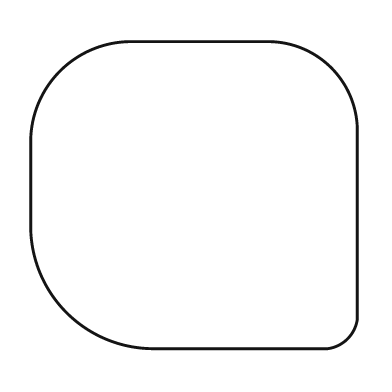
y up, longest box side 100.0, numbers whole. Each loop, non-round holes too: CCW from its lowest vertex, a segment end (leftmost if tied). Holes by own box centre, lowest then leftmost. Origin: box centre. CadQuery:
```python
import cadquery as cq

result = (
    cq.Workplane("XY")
    .moveTo(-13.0, -47.0)
    .lineTo(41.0, -47.0)
    .threePointArc((47.0, -44.0), (50.0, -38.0))
    .lineTo(50.0, 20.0)
    .threePointArc((42.0, 39.0), (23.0, 47.0))
    .lineTo(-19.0, 47.0)
    .threePointArc((-41.0, 38.0), (-50.0, 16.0))
    .lineTo(-50.0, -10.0)
    .threePointArc((-39.0, -36.0), (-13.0, -47.0))
    .close()
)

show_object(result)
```